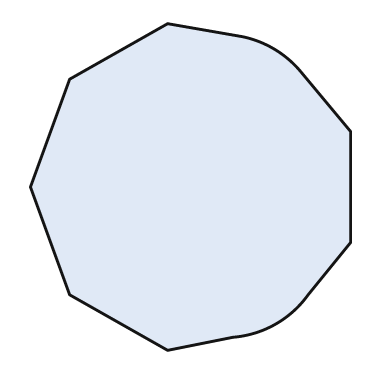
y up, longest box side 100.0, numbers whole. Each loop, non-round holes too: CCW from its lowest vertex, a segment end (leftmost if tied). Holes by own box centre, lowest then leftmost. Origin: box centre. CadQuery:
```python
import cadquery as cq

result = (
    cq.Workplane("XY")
    .moveTo(-7.0, -50.0)
    .lineTo(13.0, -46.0)
    .threePointArc((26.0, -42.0), (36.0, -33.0))
    .lineTo(49.0, -17.0)
    .lineTo(49.0, 17.0)
    .lineTo(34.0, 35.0)
    .threePointArc((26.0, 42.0), (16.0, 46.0))
    .lineTo(-7.0, 50.0)
    .lineTo(-37.0, 33.0)
    .lineTo(-49.0, 0.0)
    .lineTo(-37.0, -33.0)
    .close()
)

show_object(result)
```